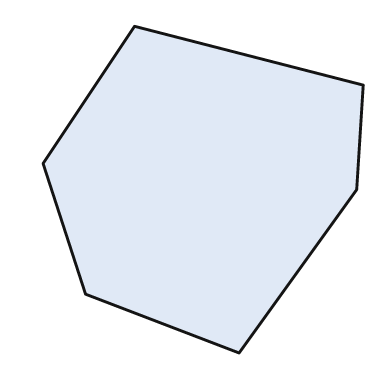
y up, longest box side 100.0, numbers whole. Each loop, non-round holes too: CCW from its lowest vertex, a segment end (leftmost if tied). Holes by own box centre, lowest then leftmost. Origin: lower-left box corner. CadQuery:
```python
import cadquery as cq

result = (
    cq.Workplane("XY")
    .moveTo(60.0, 0.0)
    .lineTo(96.0, 50.0)
    .lineTo(98.0, 82.0)
    .lineTo(28.0, 100.0)
    .lineTo(0.0, 58.0)
    .lineTo(13.0, 18.0)
    .close()
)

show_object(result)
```